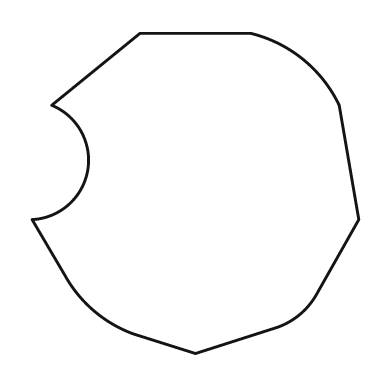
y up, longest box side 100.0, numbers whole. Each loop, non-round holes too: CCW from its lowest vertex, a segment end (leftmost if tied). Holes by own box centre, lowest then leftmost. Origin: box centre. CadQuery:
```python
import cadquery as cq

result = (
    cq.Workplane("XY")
    .moveTo(0.0, -49.0)
    .lineTo(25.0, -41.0)
    .threePointArc((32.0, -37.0), (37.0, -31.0))
    .lineTo(50.0, -8.0)
    .lineTo(44.0, 27.0)
    .threePointArc((33.0, 41.0), (17.0, 49.0))
    .lineTo(-17.0, 49.0)
    .lineTo(-44.0, 27.0)
    .threePointArc((-33.0, 7.0), (-50.0, -8.0))
    .lineTo(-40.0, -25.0)
    .threePointArc((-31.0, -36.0), (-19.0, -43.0))
    .close()
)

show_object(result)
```